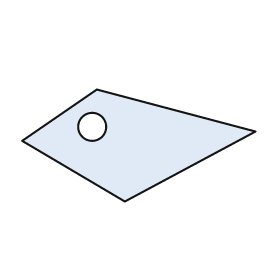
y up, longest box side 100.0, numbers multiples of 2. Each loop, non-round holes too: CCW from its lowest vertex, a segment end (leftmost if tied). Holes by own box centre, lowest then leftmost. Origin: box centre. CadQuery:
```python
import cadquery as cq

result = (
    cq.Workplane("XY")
    .moveTo(-6.0, -24.0)
    .lineTo(50.0, 6.0)
    .lineTo(-18.0, 24.0)
    .lineTo(-50.0, 2.0)
    .close()
    .moveTo(-20.0, 8.0)
    .circle(6.0)
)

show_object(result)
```